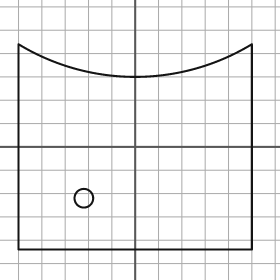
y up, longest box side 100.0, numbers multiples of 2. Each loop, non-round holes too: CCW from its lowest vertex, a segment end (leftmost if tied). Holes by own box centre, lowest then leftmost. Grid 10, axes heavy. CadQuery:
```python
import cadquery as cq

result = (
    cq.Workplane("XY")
    .moveTo(-50.0, -44.0)
    .lineTo(50.0, -44.0)
    .lineTo(50.0, 44.0)
    .threePointArc((0.0, 30.0), (-50.0, 44.0))
    .close()
    .moveTo(-22.0, -22.0)
    .circle(4.0)
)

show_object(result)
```